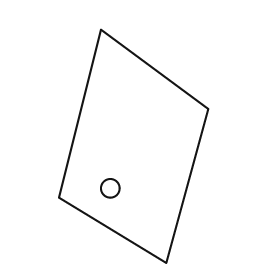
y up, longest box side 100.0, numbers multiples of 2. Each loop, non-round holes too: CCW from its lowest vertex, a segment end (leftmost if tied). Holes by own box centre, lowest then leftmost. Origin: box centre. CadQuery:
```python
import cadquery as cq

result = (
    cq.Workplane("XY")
    .moveTo(14.0, -50.0)
    .lineTo(32.0, 16.0)
    .lineTo(-14.0, 50.0)
    .lineTo(-32.0, -22.0)
    .close()
    .moveTo(-10.0, -18.0)
    .circle(4.0)
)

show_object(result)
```